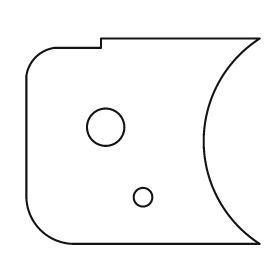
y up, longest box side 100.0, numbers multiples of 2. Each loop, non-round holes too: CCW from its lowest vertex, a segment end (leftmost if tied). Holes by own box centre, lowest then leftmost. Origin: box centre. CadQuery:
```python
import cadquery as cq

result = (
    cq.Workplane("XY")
    .moveTo(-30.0, -44.0)
    .lineTo(50.0, -44.0)
    .threePointArc((26.0, 0.0), (50.0, 44.0))
    .lineTo(-18.0, 44.0)
    .lineTo(-18.0, 40.0)
    .lineTo(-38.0, 40.0)
    .threePointArc((-46.0, 36.0), (-50.0, 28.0))
    .lineTo(-50.0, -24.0)
    .threePointArc((-44.0, -38.0), (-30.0, -44.0))
    .close()
    .moveTo(0.0, -24.0)
    .circle(4.0)
    .moveTo(-16.0, 6.0)
    .circle(8.0)
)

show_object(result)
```